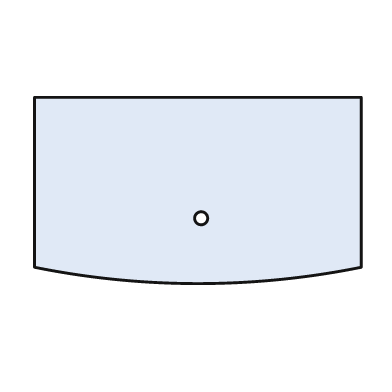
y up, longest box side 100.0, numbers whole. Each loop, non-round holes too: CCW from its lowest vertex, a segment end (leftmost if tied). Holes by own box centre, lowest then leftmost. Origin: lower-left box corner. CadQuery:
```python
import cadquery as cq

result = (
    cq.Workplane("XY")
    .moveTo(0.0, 5.0)
    .threePointArc((50.0, 0.0), (100.0, 5.0))
    .lineTo(100.0, 57.0)
    .lineTo(0.0, 57.0)
    .close()
    .moveTo(51.0, 20.0)
    .circle(2.0)
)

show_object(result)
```